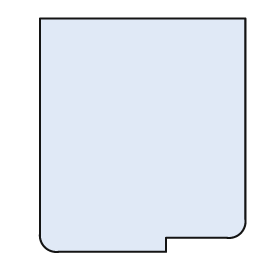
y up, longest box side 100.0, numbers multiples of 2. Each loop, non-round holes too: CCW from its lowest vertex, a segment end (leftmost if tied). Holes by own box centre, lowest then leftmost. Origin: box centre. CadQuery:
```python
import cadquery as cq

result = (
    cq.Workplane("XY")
    .moveTo(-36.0, -50.0)
    .lineTo(10.0, -50.0)
    .lineTo(10.0, -44.0)
    .lineTo(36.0, -44.0)
    .threePointArc((42.0, -42.0), (44.0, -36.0))
    .lineTo(44.0, 50.0)
    .lineTo(-44.0, 50.0)
    .lineTo(-44.0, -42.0)
    .threePointArc((-42.0, -48.0), (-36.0, -50.0))
    .close()
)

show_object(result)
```